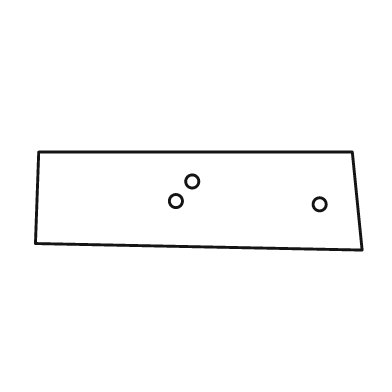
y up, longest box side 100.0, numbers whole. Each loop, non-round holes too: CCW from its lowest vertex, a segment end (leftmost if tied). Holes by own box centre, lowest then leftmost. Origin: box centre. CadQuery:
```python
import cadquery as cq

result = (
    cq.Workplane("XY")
    .moveTo(50.0, -15.0)
    .lineTo(47.0, 15.0)
    .lineTo(-49.0, 15.0)
    .lineTo(-50.0, -13.0)
    .close()
    .moveTo(37.0, -1.0)
    .circle(2.0)
    .moveTo(-7.0, 0.0)
    .circle(2.0)
    .moveTo(-2.0, 6.0)
    .circle(2.0)
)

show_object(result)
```